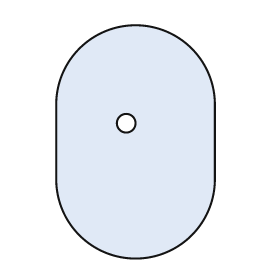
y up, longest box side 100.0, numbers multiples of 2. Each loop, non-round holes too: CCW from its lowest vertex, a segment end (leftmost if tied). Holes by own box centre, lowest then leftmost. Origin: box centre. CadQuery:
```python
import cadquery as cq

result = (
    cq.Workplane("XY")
    .moveTo(-34.0, -16.0)
    .threePointArc((0.0, -50.0), (34.0, -16.0))
    .lineTo(34.0, 16.0)
    .threePointArc((0.0, 50.0), (-34.0, 16.0))
    .close()
    .moveTo(-4.0, 8.0)
    .circle(4.0)
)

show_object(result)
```